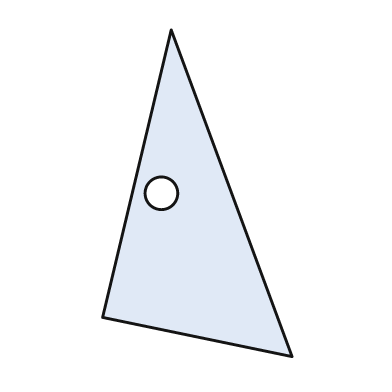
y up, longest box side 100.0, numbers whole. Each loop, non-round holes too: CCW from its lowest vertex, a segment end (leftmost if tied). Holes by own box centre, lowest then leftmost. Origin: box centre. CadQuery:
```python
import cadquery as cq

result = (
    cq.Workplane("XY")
    .moveTo(29.0, -50.0)
    .lineTo(-8.0, 50.0)
    .lineTo(-29.0, -38.0)
    .close()
    .moveTo(-11.0, 0.0)
    .circle(5.0)
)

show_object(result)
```